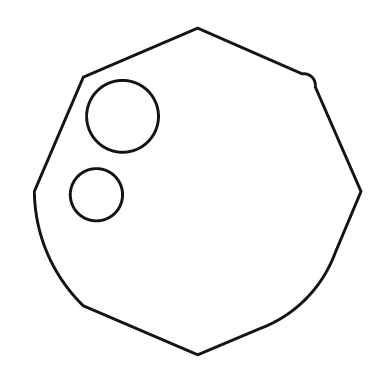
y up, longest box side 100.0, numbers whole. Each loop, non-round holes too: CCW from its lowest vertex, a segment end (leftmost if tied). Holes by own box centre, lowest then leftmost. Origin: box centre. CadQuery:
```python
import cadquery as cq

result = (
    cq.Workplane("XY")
    .moveTo(0.0, -50.0)
    .lineTo(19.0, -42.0)
    .threePointArc((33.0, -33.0), (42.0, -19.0))
    .lineTo(50.0, 0.0)
    .lineTo(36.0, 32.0)
    .threePointArc((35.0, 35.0), (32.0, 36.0))
    .lineTo(0.0, 50.0)
    .lineTo(-35.0, 35.0)
    .lineTo(-50.0, 0.0)
    .threePointArc((-46.0, -19.0), (-35.0, -35.0))
    .close()
    .moveTo(-31.0, -1.0)
    .circle(8.0)
    .moveTo(-23.0, 23.0)
    .circle(11.0)
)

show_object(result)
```